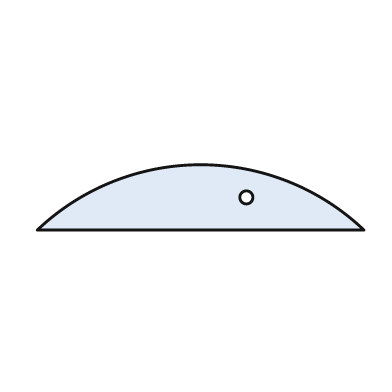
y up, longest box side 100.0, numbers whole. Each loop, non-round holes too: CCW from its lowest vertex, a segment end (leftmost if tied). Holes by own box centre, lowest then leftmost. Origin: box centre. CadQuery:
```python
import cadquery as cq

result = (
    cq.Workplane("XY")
    .moveTo(-50.0, -10.0)
    .lineTo(50.0, -10.0)
    .threePointArc((0.0, 10.0), (-50.0, -10.0))
    .close()
    .moveTo(14.0, 0.0)
    .circle(2.0)
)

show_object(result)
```